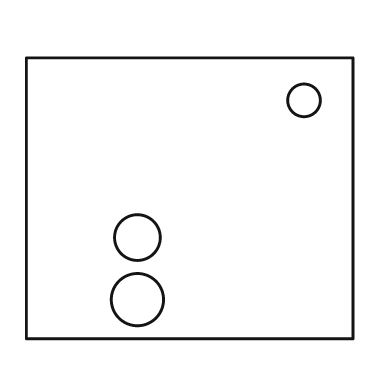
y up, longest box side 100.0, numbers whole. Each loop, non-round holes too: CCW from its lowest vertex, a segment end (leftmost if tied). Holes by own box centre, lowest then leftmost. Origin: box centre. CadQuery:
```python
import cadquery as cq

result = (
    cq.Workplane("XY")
    .moveTo(-50.0, -43.0)
    .lineTo(50.0, -43.0)
    .lineTo(50.0, 43.0)
    .lineTo(-50.0, 43.0)
    .close()
    .moveTo(-16.0, -31.0)
    .circle(8.0)
    .moveTo(-16.0, -12.0)
    .circle(7.0)
    .moveTo(35.0, 30.0)
    .circle(5.0)
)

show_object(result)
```